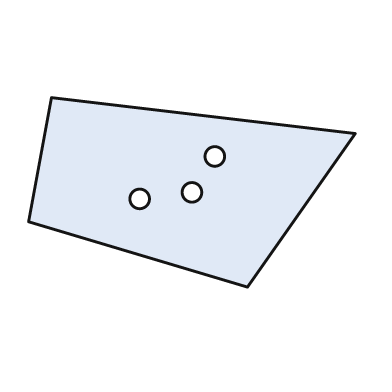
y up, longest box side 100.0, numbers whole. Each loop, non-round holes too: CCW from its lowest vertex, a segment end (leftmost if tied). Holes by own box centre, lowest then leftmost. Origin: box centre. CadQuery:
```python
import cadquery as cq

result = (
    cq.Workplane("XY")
    .moveTo(17.0, -29.0)
    .lineTo(50.0, 18.0)
    .lineTo(-43.0, 29.0)
    .lineTo(-50.0, -9.0)
    .close()
    .moveTo(-16.0, -2.0)
    .circle(3.0)
    .moveTo(0.0, 0.0)
    .circle(3.0)
    .moveTo(7.0, 11.0)
    .circle(3.0)
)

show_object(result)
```